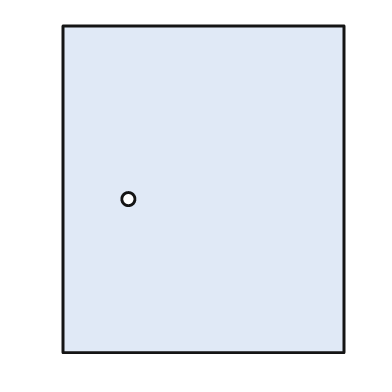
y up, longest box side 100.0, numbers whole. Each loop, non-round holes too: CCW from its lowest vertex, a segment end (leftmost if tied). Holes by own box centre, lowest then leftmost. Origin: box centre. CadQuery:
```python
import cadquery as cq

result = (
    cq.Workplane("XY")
    .moveTo(-43.0, -50.0)
    .lineTo(43.0, -50.0)
    .lineTo(43.0, 50.0)
    .lineTo(-43.0, 50.0)
    .close()
    .moveTo(-23.0, -3.0)
    .circle(2.0)
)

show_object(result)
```